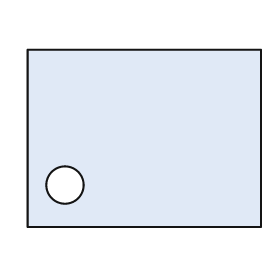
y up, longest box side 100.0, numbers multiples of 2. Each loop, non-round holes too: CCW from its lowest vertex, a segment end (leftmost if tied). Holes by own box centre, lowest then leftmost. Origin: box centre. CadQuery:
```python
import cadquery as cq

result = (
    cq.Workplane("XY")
    .moveTo(-50.0, -38.0)
    .lineTo(50.0, -38.0)
    .lineTo(50.0, 38.0)
    .lineTo(-50.0, 38.0)
    .close()
    .moveTo(-34.0, -20.0)
    .circle(8.0)
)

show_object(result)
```